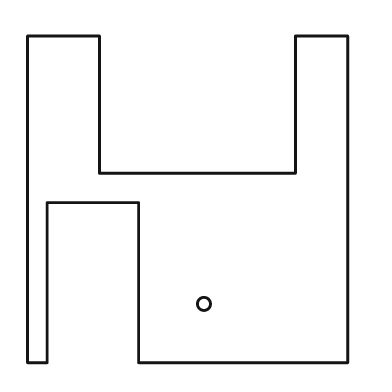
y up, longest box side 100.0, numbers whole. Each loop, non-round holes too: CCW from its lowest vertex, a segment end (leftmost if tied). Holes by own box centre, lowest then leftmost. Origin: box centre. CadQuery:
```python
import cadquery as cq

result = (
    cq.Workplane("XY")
    .moveTo(-49.0, -50.0)
    .lineTo(-43.0, -50.0)
    .lineTo(-43.0, -1.0)
    .lineTo(-15.0, -1.0)
    .lineTo(-15.0, -50.0)
    .lineTo(49.0, -50.0)
    .lineTo(49.0, 50.0)
    .lineTo(33.0, 50.0)
    .lineTo(33.0, 8.0)
    .lineTo(-27.0, 8.0)
    .lineTo(-27.0, 50.0)
    .lineTo(-49.0, 50.0)
    .close()
    .moveTo(5.0, -32.0)
    .circle(2.0)
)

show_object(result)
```